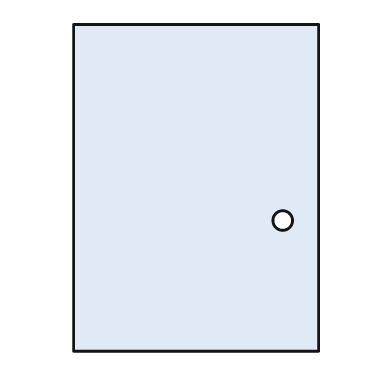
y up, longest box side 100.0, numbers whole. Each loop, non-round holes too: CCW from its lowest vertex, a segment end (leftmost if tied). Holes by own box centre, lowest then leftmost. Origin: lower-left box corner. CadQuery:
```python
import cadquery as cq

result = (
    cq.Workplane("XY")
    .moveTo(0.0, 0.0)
    .lineTo(75.0, 0.0)
    .lineTo(75.0, 100.0)
    .lineTo(0.0, 100.0)
    .close()
    .moveTo(64.0, 40.0)
    .circle(3.0)
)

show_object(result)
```